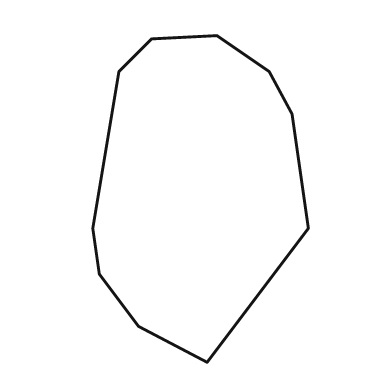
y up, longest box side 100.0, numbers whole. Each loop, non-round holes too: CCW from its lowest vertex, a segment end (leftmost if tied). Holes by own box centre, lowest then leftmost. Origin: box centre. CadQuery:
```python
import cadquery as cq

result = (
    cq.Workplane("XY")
    .moveTo(2.0, -50.0)
    .lineTo(33.0, -9.0)
    .lineTo(28.0, 26.0)
    .lineTo(21.0, 39.0)
    .lineTo(5.0, 50.0)
    .lineTo(-15.0, 49.0)
    .lineTo(-25.0, 39.0)
    .lineTo(-33.0, -9.0)
    .lineTo(-31.0, -23.0)
    .lineTo(-19.0, -39.0)
    .close()
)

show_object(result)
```